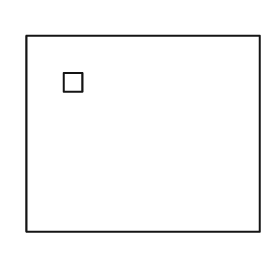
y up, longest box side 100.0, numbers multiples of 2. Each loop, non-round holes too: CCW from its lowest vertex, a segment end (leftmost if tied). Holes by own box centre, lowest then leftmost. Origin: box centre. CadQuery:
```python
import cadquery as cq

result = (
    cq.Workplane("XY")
    .moveTo(-50.0, -42.0)
    .lineTo(50.0, -42.0)
    .lineTo(50.0, 42.0)
    .lineTo(-50.0, 42.0)
    .close()
    .moveTo(-34.0, 18.0)
    .lineTo(-26.0, 18.0)
    .lineTo(-26.0, 26.0)
    .lineTo(-34.0, 26.0)
    .close()
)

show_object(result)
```